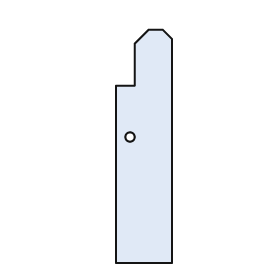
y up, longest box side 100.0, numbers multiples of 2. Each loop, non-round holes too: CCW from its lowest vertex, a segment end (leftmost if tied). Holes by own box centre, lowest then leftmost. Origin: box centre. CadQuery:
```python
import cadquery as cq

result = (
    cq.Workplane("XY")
    .moveTo(-12.0, -50.0)
    .lineTo(12.0, -50.0)
    .lineTo(12.0, 46.0)
    .lineTo(8.0, 50.0)
    .lineTo(2.0, 50.0)
    .lineTo(-4.0, 44.0)
    .lineTo(-4.0, 26.0)
    .lineTo(-12.0, 26.0)
    .close()
    .moveTo(-6.0, 4.0)
    .circle(2.0)
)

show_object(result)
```